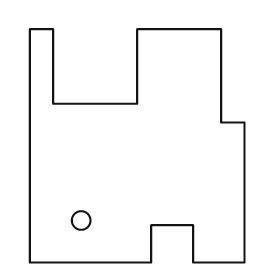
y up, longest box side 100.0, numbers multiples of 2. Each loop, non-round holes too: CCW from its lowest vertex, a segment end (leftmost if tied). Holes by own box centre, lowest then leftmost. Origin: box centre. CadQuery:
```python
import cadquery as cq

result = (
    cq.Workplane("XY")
    .moveTo(-46.0, -50.0)
    .lineTo(6.0, -50.0)
    .lineTo(6.0, -34.0)
    .lineTo(24.0, -34.0)
    .lineTo(24.0, -50.0)
    .lineTo(46.0, -50.0)
    .lineTo(46.0, 10.0)
    .lineTo(36.0, 10.0)
    .lineTo(36.0, 50.0)
    .lineTo(0.0, 50.0)
    .lineTo(0.0, 18.0)
    .lineTo(-36.0, 18.0)
    .lineTo(-36.0, 50.0)
    .lineTo(-46.0, 50.0)
    .close()
    .moveTo(-24.0, -32.0)
    .circle(4.0)
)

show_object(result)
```